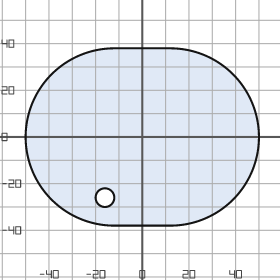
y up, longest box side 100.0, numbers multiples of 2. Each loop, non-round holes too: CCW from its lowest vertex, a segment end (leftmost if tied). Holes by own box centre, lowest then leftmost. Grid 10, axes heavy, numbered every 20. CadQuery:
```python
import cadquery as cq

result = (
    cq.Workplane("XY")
    .moveTo(-12.0, -38.0)
    .lineTo(12.0, -38.0)
    .threePointArc((50.0, 0.0), (12.0, 38.0))
    .lineTo(-12.0, 38.0)
    .threePointArc((-50.0, 0.0), (-12.0, -38.0))
    .close()
    .moveTo(-16.0, -26.0)
    .circle(4.0)
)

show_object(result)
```